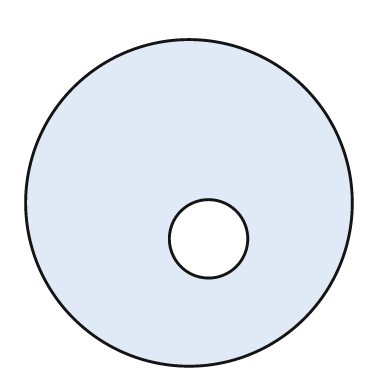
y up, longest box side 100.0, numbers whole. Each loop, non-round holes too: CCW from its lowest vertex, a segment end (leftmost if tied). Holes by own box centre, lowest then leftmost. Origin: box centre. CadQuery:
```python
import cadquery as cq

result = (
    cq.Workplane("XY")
    .moveTo(0.0, 0.0)
    .circle(50.0)
    .moveTo(6.0, -11.0)
    .circle(12.0)
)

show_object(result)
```